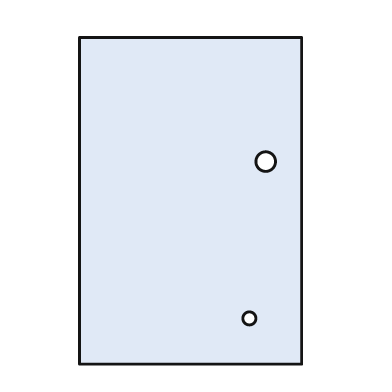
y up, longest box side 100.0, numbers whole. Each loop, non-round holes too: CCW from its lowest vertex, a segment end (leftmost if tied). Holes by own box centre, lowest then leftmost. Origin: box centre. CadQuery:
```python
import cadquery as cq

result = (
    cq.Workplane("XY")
    .moveTo(-34.0, -50.0)
    .lineTo(34.0, -50.0)
    .lineTo(34.0, 50.0)
    .lineTo(-34.0, 50.0)
    .close()
    .moveTo(18.0, -36.0)
    .circle(2.0)
    .moveTo(23.0, 12.0)
    .circle(3.0)
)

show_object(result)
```